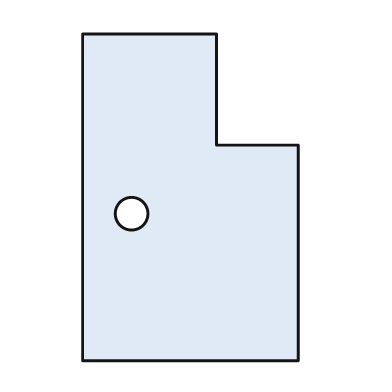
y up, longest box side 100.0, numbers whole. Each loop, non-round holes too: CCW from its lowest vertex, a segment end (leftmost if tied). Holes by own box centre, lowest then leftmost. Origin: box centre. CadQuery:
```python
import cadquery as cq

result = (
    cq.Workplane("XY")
    .moveTo(-33.0, -50.0)
    .lineTo(33.0, -50.0)
    .lineTo(33.0, 16.0)
    .lineTo(8.0, 16.0)
    .lineTo(8.0, 50.0)
    .lineTo(-33.0, 50.0)
    .close()
    .moveTo(-18.0, -5.0)
    .circle(5.0)
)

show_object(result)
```